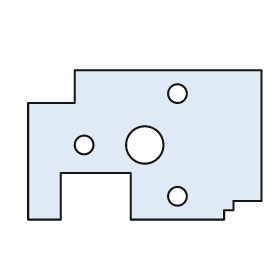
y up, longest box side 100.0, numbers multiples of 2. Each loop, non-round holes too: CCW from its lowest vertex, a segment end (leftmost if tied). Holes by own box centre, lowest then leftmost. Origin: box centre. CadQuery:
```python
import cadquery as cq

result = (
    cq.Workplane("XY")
    .moveTo(-50.0, -32.0)
    .lineTo(-36.0, -32.0)
    .lineTo(-36.0, -12.0)
    .lineTo(-6.0, -12.0)
    .lineTo(-6.0, -32.0)
    .lineTo(34.0, -32.0)
    .lineTo(34.0, -28.0)
    .lineTo(38.0, -28.0)
    .lineTo(38.0, -24.0)
    .lineTo(50.0, -24.0)
    .lineTo(50.0, 32.0)
    .lineTo(-30.0, 32.0)
    .lineTo(-30.0, 18.0)
    .lineTo(-50.0, 18.0)
    .close()
    .moveTo(14.0, -22.0)
    .circle(4.0)
    .moveTo(-26.0, 0.0)
    .circle(4.0)
    .moveTo(0.0, 0.0)
    .circle(8.0)
    .moveTo(14.0, 22.0)
    .circle(4.0)
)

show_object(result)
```